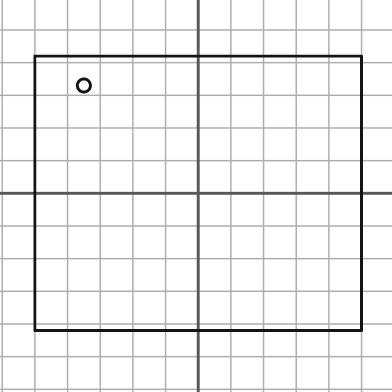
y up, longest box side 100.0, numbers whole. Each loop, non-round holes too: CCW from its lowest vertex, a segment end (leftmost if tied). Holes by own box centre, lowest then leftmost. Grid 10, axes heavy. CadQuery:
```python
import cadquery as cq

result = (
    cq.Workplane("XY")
    .moveTo(-50.0, -42.0)
    .lineTo(50.0, -42.0)
    .lineTo(50.0, 42.0)
    .lineTo(-50.0, 42.0)
    .close()
    .moveTo(-35.0, 33.0)
    .circle(2.0)
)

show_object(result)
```